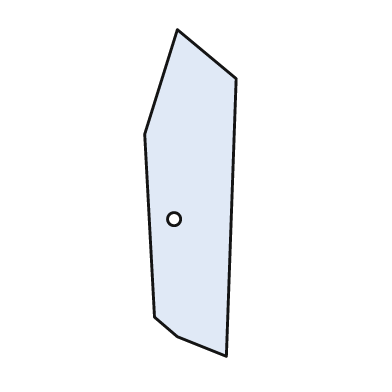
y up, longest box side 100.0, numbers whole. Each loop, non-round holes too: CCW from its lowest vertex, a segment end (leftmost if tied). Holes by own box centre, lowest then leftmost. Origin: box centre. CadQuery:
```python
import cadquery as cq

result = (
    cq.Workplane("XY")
    .moveTo(11.0, -50.0)
    .lineTo(14.0, 35.0)
    .lineTo(-4.0, 50.0)
    .lineTo(-14.0, 18.0)
    .lineTo(-11.0, -38.0)
    .lineTo(-4.0, -44.0)
    .close()
    .moveTo(-5.0, -8.0)
    .circle(2.0)
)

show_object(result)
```